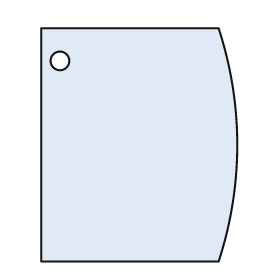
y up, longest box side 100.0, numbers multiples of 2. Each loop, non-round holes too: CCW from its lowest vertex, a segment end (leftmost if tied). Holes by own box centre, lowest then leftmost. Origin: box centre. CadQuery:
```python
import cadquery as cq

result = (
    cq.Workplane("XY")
    .moveTo(-42.0, -50.0)
    .lineTo(34.0, -50.0)
    .threePointArc((42.0, 0.0), (34.0, 50.0))
    .lineTo(-42.0, 50.0)
    .close()
    .moveTo(-34.0, 36.0)
    .circle(4.0)
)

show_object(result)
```